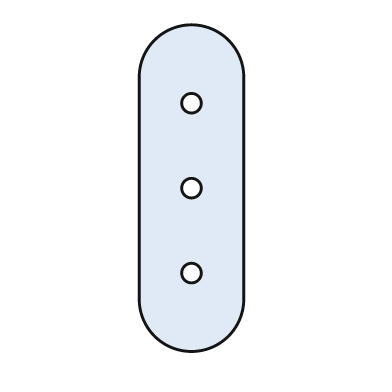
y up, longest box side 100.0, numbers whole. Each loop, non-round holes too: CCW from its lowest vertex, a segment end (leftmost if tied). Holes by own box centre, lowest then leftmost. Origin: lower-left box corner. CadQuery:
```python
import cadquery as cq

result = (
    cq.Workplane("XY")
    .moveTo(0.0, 16.0)
    .threePointArc((16.0, 0.0), (32.0, 16.0))
    .lineTo(32.0, 84.0)
    .threePointArc((16.0, 100.0), (0.0, 84.0))
    .close()
    .moveTo(16.0, 24.0)
    .circle(3.0)
    .moveTo(16.0, 50.0)
    .circle(3.0)
    .moveTo(16.0, 76.0)
    .circle(3.0)
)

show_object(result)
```